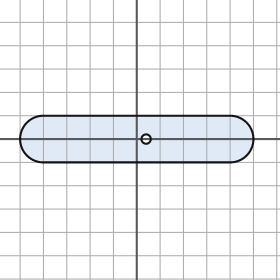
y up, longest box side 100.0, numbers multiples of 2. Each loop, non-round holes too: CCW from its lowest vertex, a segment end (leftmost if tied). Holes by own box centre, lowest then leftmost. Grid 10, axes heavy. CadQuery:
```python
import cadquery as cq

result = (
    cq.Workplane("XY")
    .moveTo(-40.0, -10.0)
    .lineTo(40.0, -10.0)
    .threePointArc((50.0, 0.0), (40.0, 10.0))
    .lineTo(-40.0, 10.0)
    .threePointArc((-50.0, 0.0), (-40.0, -10.0))
    .close()
    .moveTo(4.0, 0.0)
    .circle(2.0)
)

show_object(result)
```